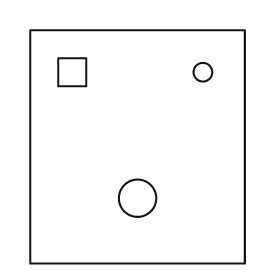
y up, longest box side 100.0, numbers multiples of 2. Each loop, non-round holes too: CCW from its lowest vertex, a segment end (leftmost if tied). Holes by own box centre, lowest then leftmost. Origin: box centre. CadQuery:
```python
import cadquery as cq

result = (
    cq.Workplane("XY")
    .moveTo(-46.0, -50.0)
    .lineTo(46.0, -50.0)
    .lineTo(46.0, 50.0)
    .lineTo(-46.0, 50.0)
    .close()
    .moveTo(0.0, -22.0)
    .circle(8.0)
    .moveTo(-34.0, 26.0)
    .lineTo(-22.0, 26.0)
    .lineTo(-22.0, 38.0)
    .lineTo(-34.0, 38.0)
    .close()
    .moveTo(28.0, 32.0)
    .circle(4.0)
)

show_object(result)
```